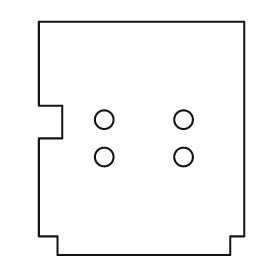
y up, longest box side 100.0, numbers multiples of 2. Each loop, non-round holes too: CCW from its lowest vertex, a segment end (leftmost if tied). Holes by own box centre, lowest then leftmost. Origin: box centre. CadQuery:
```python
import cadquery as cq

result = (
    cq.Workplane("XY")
    .moveTo(-36.0, -50.0)
    .lineTo(38.0, -50.0)
    .lineTo(38.0, -42.0)
    .lineTo(44.0, -42.0)
    .lineTo(44.0, 50.0)
    .lineTo(-44.0, 50.0)
    .lineTo(-44.0, 14.0)
    .lineTo(-34.0, 14.0)
    .lineTo(-34.0, 0.0)
    .lineTo(-44.0, 0.0)
    .lineTo(-44.0, -42.0)
    .lineTo(-36.0, -42.0)
    .close()
    .moveTo(-16.0, -8.0)
    .circle(4.0)
    .moveTo(18.0, -8.0)
    .circle(4.0)
    .moveTo(-16.0, 8.0)
    .circle(4.0)
    .moveTo(18.0, 8.0)
    .circle(4.0)
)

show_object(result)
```